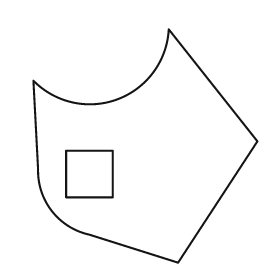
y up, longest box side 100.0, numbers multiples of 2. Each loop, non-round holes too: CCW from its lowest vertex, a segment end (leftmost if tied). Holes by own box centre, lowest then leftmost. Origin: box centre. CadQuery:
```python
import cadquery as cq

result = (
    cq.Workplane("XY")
    .moveTo(14.0, -50.0)
    .lineTo(48.0, 2.0)
    .lineTo(10.0, 50.0)
    .threePointArc((-12.0, 20.0), (-48.0, 28.0))
    .lineTo(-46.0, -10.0)
    .threePointArc((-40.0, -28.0), (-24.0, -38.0))
    .close()
    .moveTo(-34.0, -22.0)
    .lineTo(-14.0, -22.0)
    .lineTo(-14.0, -2.0)
    .lineTo(-34.0, -2.0)
    .close()
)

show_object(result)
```